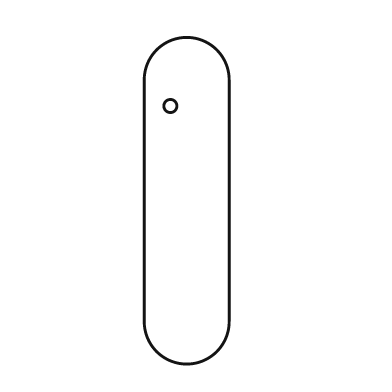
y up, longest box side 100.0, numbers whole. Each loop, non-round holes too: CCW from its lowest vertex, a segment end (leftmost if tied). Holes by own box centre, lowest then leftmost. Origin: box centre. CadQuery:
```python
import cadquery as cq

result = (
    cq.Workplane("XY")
    .moveTo(-13.0, -37.0)
    .threePointArc((0.0, -50.0), (13.0, -37.0))
    .lineTo(13.0, 37.0)
    .threePointArc((0.0, 50.0), (-13.0, 37.0))
    .close()
    .moveTo(-5.0, 29.0)
    .circle(2.0)
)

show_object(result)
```